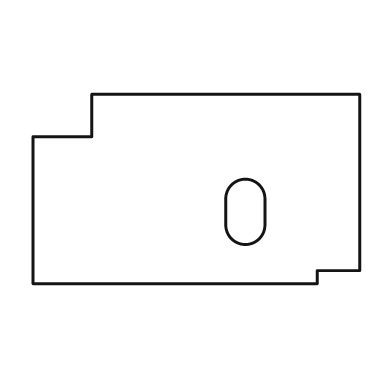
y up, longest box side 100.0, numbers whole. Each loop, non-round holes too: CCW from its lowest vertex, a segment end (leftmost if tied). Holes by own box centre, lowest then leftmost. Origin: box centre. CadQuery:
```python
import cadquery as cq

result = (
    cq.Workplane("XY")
    .moveTo(-50.0, -29.0)
    .lineTo(37.0, -29.0)
    .lineTo(37.0, -25.0)
    .lineTo(50.0, -25.0)
    .lineTo(50.0, 29.0)
    .lineTo(-32.0, 29.0)
    .lineTo(-32.0, 16.0)
    .lineTo(-50.0, 16.0)
    .close()
    .moveTo(9.0, -11.0)
    .threePointArc((15.0, -17.0), (21.0, -11.0))
    .lineTo(21.0, -3.0)
    .threePointArc((15.0, 3.0), (9.0, -3.0))
    .close()
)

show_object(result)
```